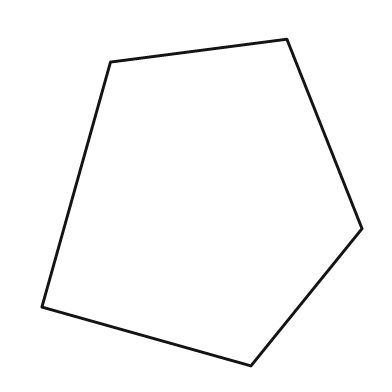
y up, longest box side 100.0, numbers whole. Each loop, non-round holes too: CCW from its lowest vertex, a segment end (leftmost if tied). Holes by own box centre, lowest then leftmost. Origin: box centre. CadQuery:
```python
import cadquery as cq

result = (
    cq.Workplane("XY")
    .moveTo(15.0, -50.0)
    .lineTo(49.0, -8.0)
    .lineTo(26.0, 50.0)
    .lineTo(-28.0, 43.0)
    .lineTo(-49.0, -32.0)
    .close()
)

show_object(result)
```